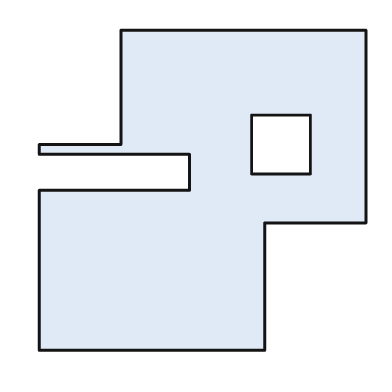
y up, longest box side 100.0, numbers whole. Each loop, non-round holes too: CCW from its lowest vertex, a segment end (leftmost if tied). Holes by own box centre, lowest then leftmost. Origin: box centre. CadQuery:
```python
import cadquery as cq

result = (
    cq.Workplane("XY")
    .moveTo(-50.0, -49.0)
    .lineTo(19.0, -49.0)
    .lineTo(19.0, -10.0)
    .lineTo(50.0, -10.0)
    .lineTo(50.0, 49.0)
    .lineTo(-25.0, 49.0)
    .lineTo(-25.0, 14.0)
    .lineTo(-50.0, 14.0)
    .lineTo(-50.0, 11.0)
    .lineTo(-4.0, 11.0)
    .lineTo(-4.0, 0.0)
    .lineTo(-50.0, 0.0)
    .close()
    .moveTo(15.0, 5.0)
    .lineTo(33.0, 5.0)
    .lineTo(33.0, 23.0)
    .lineTo(15.0, 23.0)
    .close()
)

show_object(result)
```